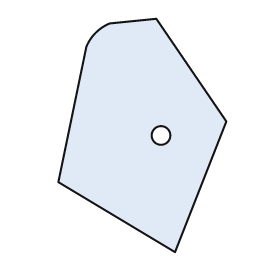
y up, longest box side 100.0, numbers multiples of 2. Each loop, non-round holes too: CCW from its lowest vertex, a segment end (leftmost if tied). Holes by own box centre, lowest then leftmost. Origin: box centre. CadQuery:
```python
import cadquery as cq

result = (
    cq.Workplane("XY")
    .moveTo(14.0, -50.0)
    .lineTo(36.0, 6.0)
    .lineTo(6.0, 50.0)
    .lineTo(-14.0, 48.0)
    .threePointArc((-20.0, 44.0), (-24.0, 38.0))
    .lineTo(-36.0, -20.0)
    .close()
    .moveTo(8.0, 0.0)
    .circle(4.0)
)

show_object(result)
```